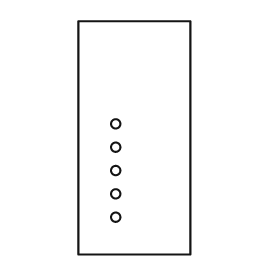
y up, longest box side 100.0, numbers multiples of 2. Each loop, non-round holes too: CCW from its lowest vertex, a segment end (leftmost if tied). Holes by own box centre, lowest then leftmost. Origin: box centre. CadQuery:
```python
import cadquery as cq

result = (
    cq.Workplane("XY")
    .moveTo(-24.0, -50.0)
    .lineTo(24.0, -50.0)
    .lineTo(24.0, 50.0)
    .lineTo(-24.0, 50.0)
    .close()
    .moveTo(-8.0, -34.0)
    .circle(2.0)
    .moveTo(-8.0, -24.0)
    .circle(2.0)
    .moveTo(-8.0, -14.0)
    .circle(2.0)
    .moveTo(-8.0, -4.0)
    .circle(2.0)
    .moveTo(-8.0, 6.0)
    .circle(2.0)
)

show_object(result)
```